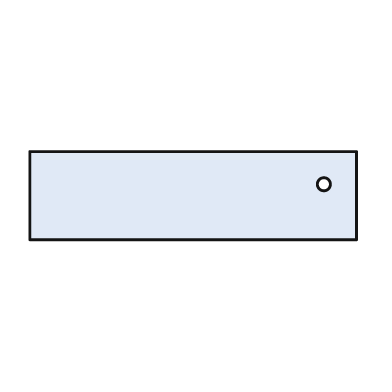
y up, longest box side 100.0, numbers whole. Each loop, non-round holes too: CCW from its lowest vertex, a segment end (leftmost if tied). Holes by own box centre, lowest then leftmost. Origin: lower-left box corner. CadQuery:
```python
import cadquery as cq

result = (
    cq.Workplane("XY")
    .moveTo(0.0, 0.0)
    .lineTo(100.0, 0.0)
    .lineTo(100.0, 27.0)
    .lineTo(0.0, 27.0)
    .close()
    .moveTo(90.0, 17.0)
    .circle(2.0)
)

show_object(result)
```